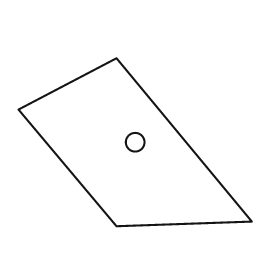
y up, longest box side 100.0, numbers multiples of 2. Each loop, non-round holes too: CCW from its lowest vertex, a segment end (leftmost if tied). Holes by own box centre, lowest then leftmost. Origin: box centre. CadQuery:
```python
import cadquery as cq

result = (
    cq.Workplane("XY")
    .moveTo(-8.0, -36.0)
    .lineTo(50.0, -34.0)
    .lineTo(-8.0, 36.0)
    .lineTo(-50.0, 14.0)
    .close()
    .moveTo(0.0, 0.0)
    .circle(4.0)
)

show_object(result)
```